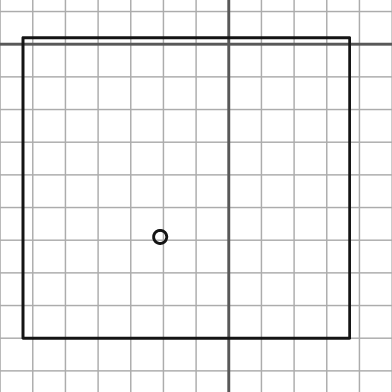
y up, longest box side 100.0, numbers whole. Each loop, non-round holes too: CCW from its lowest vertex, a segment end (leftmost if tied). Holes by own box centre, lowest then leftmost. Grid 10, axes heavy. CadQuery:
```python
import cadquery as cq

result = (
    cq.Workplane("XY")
    .moveTo(-63.0, -90.0)
    .lineTo(37.0, -90.0)
    .lineTo(37.0, 2.0)
    .lineTo(-63.0, 2.0)
    .close()
    .moveTo(-21.0, -59.0)
    .circle(2.0)
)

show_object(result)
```